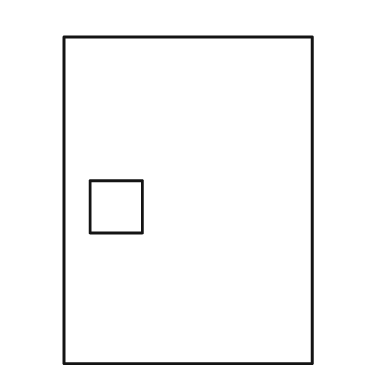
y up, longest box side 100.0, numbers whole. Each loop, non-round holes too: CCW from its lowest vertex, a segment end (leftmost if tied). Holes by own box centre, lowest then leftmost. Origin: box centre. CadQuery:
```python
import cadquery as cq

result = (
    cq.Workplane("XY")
    .moveTo(-38.0, -50.0)
    .lineTo(38.0, -50.0)
    .lineTo(38.0, 50.0)
    .lineTo(-38.0, 50.0)
    .close()
    .moveTo(-30.0, -10.0)
    .lineTo(-14.0, -10.0)
    .lineTo(-14.0, 6.0)
    .lineTo(-30.0, 6.0)
    .close()
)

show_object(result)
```